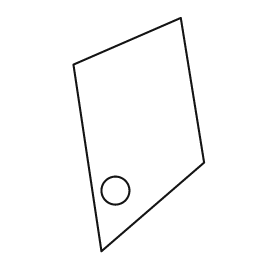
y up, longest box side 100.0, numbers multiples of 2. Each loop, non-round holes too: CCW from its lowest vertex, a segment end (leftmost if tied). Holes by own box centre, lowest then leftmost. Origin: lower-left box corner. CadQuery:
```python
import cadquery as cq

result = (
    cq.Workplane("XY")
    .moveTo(12.0, 0.0)
    .lineTo(56.0, 38.0)
    .lineTo(46.0, 100.0)
    .lineTo(0.0, 80.0)
    .close()
    .moveTo(18.0, 26.0)
    .circle(6.0)
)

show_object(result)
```